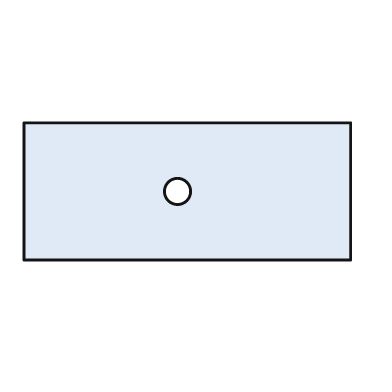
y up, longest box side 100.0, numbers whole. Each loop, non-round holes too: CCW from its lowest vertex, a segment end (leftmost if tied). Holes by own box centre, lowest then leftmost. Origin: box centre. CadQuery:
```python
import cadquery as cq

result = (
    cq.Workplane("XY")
    .moveTo(-50.0, -21.0)
    .lineTo(50.0, -21.0)
    .lineTo(50.0, 21.0)
    .lineTo(-50.0, 21.0)
    .close()
    .moveTo(-3.0, 0.0)
    .circle(4.0)
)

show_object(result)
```